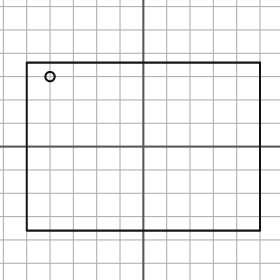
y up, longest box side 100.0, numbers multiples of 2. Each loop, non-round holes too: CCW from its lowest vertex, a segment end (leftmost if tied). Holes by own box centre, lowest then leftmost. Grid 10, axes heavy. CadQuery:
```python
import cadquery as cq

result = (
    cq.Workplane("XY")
    .moveTo(-50.0, -36.0)
    .lineTo(50.0, -36.0)
    .lineTo(50.0, 36.0)
    .lineTo(-50.0, 36.0)
    .close()
    .moveTo(-40.0, 30.0)
    .circle(2.0)
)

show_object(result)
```